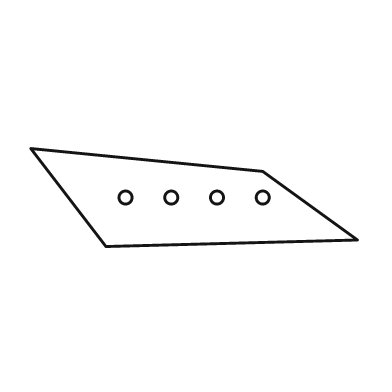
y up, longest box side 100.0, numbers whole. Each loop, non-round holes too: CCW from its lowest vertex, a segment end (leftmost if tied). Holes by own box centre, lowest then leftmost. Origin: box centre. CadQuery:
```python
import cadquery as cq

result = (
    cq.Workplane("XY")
    .moveTo(-27.0, -15.0)
    .lineTo(50.0, -13.0)
    .lineTo(21.0, 8.0)
    .lineTo(-50.0, 15.0)
    .close()
    .moveTo(-21.0, 0.0)
    .circle(2.0)
    .moveTo(-7.0, 0.0)
    .circle(2.0)
    .moveTo(7.0, 0.0)
    .circle(2.0)
    .moveTo(21.0, 0.0)
    .circle(2.0)
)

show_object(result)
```